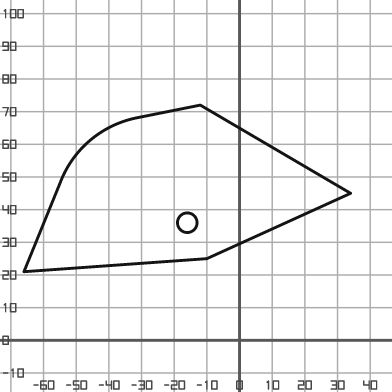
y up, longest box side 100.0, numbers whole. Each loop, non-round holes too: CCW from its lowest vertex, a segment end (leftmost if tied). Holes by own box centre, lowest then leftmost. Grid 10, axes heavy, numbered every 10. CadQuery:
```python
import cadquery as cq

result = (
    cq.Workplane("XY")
    .moveTo(-66.0, 21.0)
    .lineTo(-10.0, 25.0)
    .lineTo(34.0, 45.0)
    .lineTo(-12.0, 72.0)
    .lineTo(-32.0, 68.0)
    .threePointArc((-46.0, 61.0), (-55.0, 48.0))
    .close()
    .moveTo(-16.0, 36.0)
    .circle(3.0)
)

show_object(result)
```